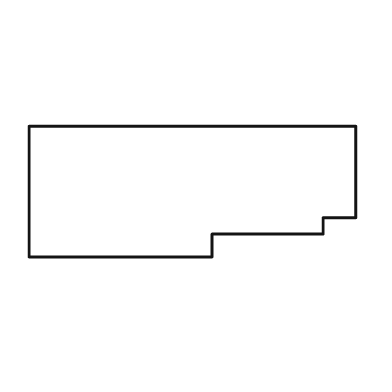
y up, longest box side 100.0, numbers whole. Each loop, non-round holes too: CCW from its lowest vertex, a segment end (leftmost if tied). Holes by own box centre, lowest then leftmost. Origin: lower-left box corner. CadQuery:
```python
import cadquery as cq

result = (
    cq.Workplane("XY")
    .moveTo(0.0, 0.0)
    .lineTo(56.0, 0.0)
    .lineTo(56.0, 7.0)
    .lineTo(90.0, 7.0)
    .lineTo(90.0, 12.0)
    .lineTo(100.0, 12.0)
    .lineTo(100.0, 40.0)
    .lineTo(0.0, 40.0)
    .close()
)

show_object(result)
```